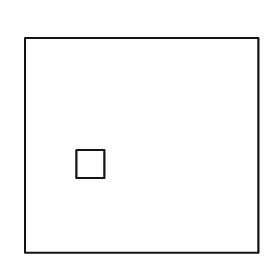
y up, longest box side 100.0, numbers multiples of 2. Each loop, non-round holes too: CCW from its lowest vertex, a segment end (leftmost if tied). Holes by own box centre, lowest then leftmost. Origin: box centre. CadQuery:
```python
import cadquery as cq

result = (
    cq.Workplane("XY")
    .moveTo(-50.0, -46.0)
    .lineTo(50.0, -46.0)
    .lineTo(50.0, 46.0)
    .lineTo(-50.0, 46.0)
    .close()
    .moveTo(-28.0, -14.0)
    .lineTo(-16.0, -14.0)
    .lineTo(-16.0, -2.0)
    .lineTo(-28.0, -2.0)
    .close()
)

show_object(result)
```